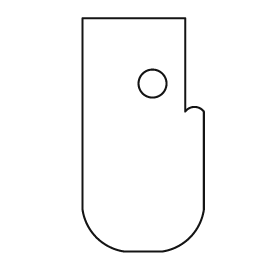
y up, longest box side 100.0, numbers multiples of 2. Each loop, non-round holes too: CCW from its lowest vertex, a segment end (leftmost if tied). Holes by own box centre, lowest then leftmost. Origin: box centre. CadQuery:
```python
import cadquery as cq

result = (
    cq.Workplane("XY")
    .moveTo(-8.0, -50.0)
    .lineTo(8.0, -50.0)
    .threePointArc((20.0, -44.0), (26.0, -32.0))
    .lineTo(26.0, 10.0)
    .threePointArc((22.0, 12.0), (18.0, 10.0))
    .lineTo(18.0, 50.0)
    .lineTo(-26.0, 50.0)
    .lineTo(-26.0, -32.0)
    .threePointArc((-20.0, -44.0), (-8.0, -50.0))
    .close()
    .moveTo(4.0, 22.0)
    .circle(6.0)
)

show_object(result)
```